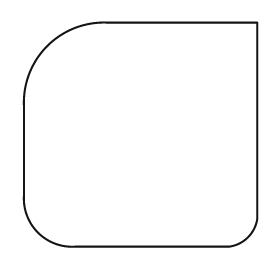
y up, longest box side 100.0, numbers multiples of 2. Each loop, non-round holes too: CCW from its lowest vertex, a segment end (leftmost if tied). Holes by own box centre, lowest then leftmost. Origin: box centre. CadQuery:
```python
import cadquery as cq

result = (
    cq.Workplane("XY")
    .moveTo(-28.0, -48.0)
    .lineTo(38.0, -48.0)
    .threePointArc((46.0, -44.0), (50.0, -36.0))
    .lineTo(50.0, 48.0)
    .lineTo(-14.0, 48.0)
    .threePointArc((-40.0, 38.0), (-50.0, 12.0))
    .lineTo(-50.0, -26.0)
    .threePointArc((-44.0, -42.0), (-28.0, -48.0))
    .close()
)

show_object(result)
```